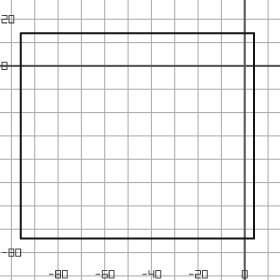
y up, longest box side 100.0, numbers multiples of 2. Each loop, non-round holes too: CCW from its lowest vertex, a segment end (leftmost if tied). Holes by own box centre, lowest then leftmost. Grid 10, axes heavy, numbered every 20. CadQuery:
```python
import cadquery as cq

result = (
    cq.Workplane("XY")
    .moveTo(-96.0, -74.0)
    .lineTo(4.0, -74.0)
    .lineTo(4.0, 14.0)
    .lineTo(-96.0, 14.0)
    .close()
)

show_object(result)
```